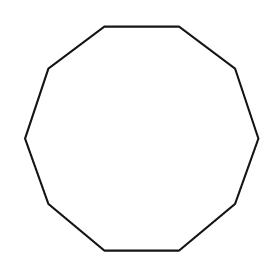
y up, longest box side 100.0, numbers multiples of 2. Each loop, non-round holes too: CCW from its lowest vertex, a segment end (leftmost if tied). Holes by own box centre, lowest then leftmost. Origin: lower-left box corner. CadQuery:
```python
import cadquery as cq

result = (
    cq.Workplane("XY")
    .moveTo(34.0, 0.0)
    .lineTo(66.0, 0.0)
    .lineTo(90.0, 20.0)
    .lineTo(100.0, 48.0)
    .lineTo(90.0, 78.0)
    .lineTo(66.0, 96.0)
    .lineTo(34.0, 96.0)
    .lineTo(10.0, 78.0)
    .lineTo(0.0, 48.0)
    .lineTo(10.0, 20.0)
    .close()
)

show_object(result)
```